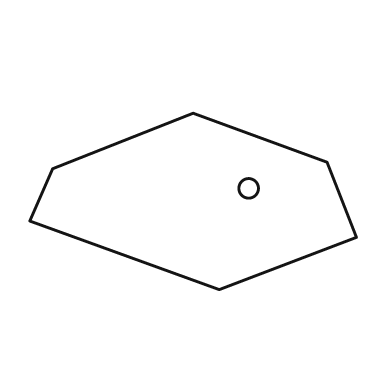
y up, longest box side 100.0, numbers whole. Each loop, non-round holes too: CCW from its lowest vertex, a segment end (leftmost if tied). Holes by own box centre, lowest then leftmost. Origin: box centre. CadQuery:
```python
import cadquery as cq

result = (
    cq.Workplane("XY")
    .moveTo(8.0, -27.0)
    .lineTo(50.0, -11.0)
    .lineTo(41.0, 12.0)
    .lineTo(0.0, 27.0)
    .lineTo(-43.0, 10.0)
    .lineTo(-50.0, -6.0)
    .close()
    .moveTo(17.0, 4.0)
    .circle(3.0)
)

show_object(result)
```